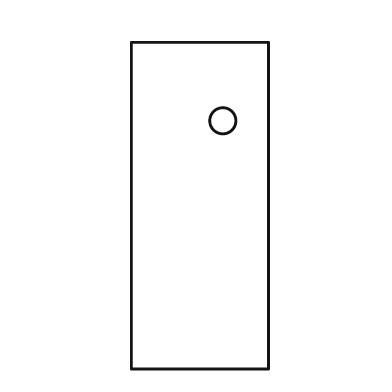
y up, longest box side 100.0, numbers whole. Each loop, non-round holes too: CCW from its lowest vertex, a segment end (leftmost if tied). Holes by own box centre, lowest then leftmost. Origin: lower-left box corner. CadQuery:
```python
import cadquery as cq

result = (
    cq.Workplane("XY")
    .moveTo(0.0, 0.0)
    .lineTo(42.0, 0.0)
    .lineTo(42.0, 100.0)
    .lineTo(0.0, 100.0)
    .close()
    .moveTo(28.0, 76.0)
    .circle(4.0)
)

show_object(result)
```